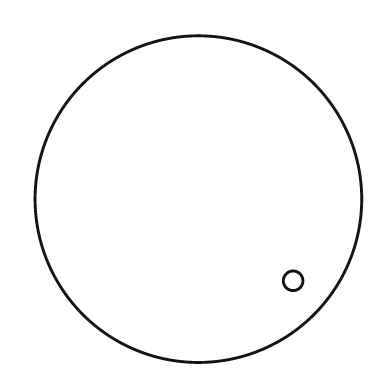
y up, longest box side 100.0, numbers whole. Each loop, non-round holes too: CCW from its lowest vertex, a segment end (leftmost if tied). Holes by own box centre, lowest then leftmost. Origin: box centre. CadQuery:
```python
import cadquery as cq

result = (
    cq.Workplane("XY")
    .moveTo(0.0, 0.0)
    .circle(50.0)
    .moveTo(29.0, -25.0)
    .circle(3.0)
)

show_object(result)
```